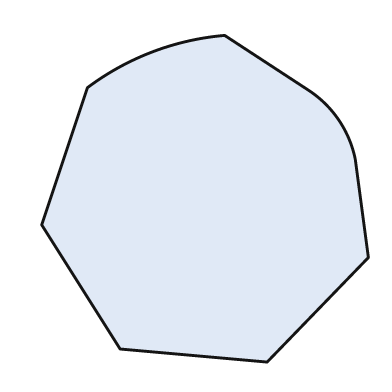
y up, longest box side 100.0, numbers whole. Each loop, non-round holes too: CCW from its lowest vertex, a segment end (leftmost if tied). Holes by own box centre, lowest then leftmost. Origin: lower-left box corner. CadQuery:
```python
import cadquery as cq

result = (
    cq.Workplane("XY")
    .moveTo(69.0, 0.0)
    .lineTo(100.0, 32.0)
    .lineTo(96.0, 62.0)
    .threePointArc((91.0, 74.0), (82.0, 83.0))
    .lineTo(56.0, 100.0)
    .threePointArc((34.0, 95.0), (14.0, 84.0))
    .lineTo(0.0, 42.0)
    .lineTo(24.0, 4.0)
    .close()
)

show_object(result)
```